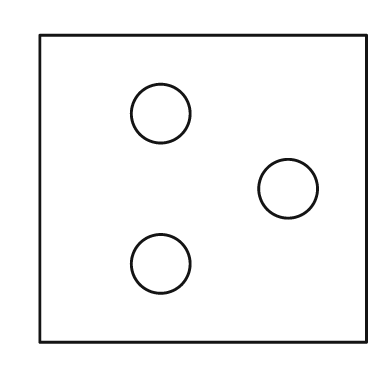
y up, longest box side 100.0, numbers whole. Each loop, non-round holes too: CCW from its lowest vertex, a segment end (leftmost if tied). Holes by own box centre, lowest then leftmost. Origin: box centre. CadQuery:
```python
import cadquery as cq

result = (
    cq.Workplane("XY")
    .moveTo(-50.0, -47.0)
    .lineTo(50.0, -47.0)
    .lineTo(50.0, 47.0)
    .lineTo(-50.0, 47.0)
    .close()
    .moveTo(-13.0, -23.0)
    .circle(9.0)
    .moveTo(26.0, 0.0)
    .circle(9.0)
    .moveTo(-13.0, 23.0)
    .circle(9.0)
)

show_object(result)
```